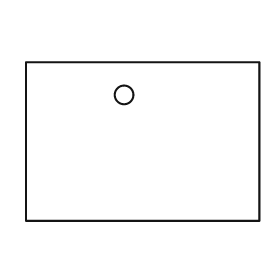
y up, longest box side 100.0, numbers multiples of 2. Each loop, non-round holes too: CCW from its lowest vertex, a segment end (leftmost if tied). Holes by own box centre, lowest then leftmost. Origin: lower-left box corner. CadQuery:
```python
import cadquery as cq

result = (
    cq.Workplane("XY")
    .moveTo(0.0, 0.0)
    .lineTo(100.0, 0.0)
    .lineTo(100.0, 68.0)
    .lineTo(0.0, 68.0)
    .close()
    .moveTo(42.0, 54.0)
    .circle(4.0)
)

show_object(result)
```